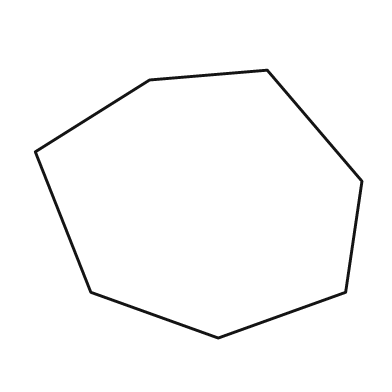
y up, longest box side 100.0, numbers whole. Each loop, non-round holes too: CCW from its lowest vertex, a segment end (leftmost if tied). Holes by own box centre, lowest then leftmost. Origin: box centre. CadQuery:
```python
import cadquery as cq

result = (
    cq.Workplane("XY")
    .moveTo(6.0, -41.0)
    .lineTo(45.0, -27.0)
    .lineTo(50.0, 7.0)
    .lineTo(21.0, 41.0)
    .lineTo(-15.0, 38.0)
    .lineTo(-50.0, 16.0)
    .lineTo(-33.0, -27.0)
    .close()
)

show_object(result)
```